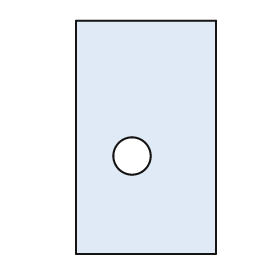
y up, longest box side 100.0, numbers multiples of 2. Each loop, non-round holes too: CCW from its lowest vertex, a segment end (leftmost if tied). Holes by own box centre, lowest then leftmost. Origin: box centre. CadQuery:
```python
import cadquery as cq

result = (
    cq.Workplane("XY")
    .moveTo(-30.0, -50.0)
    .lineTo(30.0, -50.0)
    .lineTo(30.0, 50.0)
    .lineTo(-30.0, 50.0)
    .close()
    .moveTo(-6.0, -8.0)
    .circle(8.0)
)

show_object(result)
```